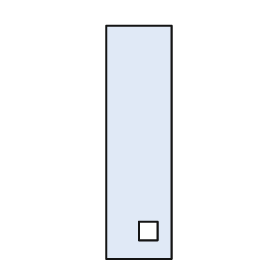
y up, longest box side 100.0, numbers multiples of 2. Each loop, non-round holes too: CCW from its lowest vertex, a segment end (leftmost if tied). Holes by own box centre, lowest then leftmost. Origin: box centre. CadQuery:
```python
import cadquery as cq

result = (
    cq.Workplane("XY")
    .moveTo(-14.0, -50.0)
    .lineTo(14.0, -50.0)
    .lineTo(14.0, 50.0)
    .lineTo(-14.0, 50.0)
    .close()
    .moveTo(0.0, -42.0)
    .lineTo(8.0, -42.0)
    .lineTo(8.0, -34.0)
    .lineTo(0.0, -34.0)
    .close()
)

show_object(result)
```